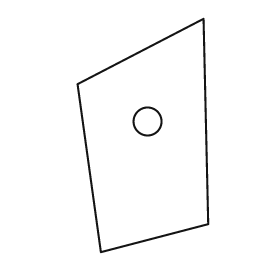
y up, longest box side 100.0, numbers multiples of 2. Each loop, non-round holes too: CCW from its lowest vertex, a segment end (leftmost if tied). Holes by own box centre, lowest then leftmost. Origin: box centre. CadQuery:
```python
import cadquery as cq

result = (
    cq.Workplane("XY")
    .moveTo(-18.0, -50.0)
    .lineTo(28.0, -38.0)
    .lineTo(26.0, 50.0)
    .lineTo(-28.0, 22.0)
    .close()
    .moveTo(2.0, 6.0)
    .circle(6.0)
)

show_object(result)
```